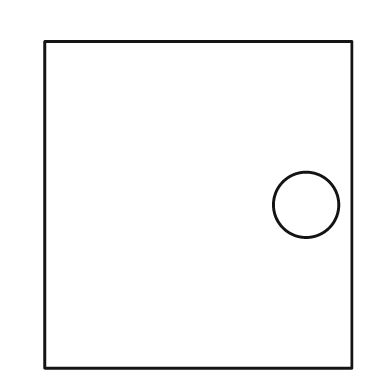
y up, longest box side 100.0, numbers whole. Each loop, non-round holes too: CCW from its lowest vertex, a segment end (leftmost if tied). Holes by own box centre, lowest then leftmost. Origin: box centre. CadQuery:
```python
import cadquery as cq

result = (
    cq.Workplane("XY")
    .moveTo(-47.0, -50.0)
    .lineTo(47.0, -50.0)
    .lineTo(47.0, 50.0)
    .lineTo(-47.0, 50.0)
    .close()
    .moveTo(33.0, 0.0)
    .circle(10.0)
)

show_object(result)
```